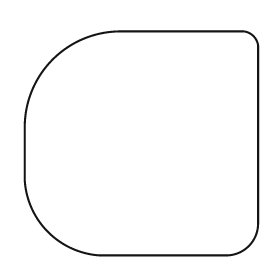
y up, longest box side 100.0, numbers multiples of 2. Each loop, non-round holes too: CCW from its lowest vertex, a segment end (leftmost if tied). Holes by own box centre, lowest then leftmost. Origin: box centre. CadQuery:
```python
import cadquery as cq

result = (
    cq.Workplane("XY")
    .moveTo(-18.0, -48.0)
    .lineTo(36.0, -48.0)
    .threePointArc((46.0, -44.0), (50.0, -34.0))
    .lineTo(50.0, 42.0)
    .threePointArc((48.0, 46.0), (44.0, 48.0))
    .lineTo(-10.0, 48.0)
    .threePointArc((-38.0, 36.0), (-50.0, 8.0))
    .lineTo(-50.0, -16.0)
    .threePointArc((-40.0, -38.0), (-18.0, -48.0))
    .close()
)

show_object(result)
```